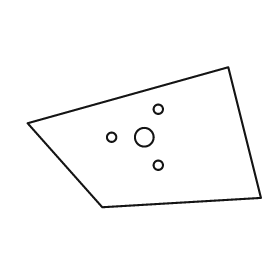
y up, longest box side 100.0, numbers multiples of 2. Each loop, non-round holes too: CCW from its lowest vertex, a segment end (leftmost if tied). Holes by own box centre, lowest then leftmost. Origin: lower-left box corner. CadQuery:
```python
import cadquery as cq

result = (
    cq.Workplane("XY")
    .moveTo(32.0, 0.0)
    .lineTo(100.0, 4.0)
    .lineTo(86.0, 60.0)
    .lineTo(0.0, 36.0)
    .close()
    .moveTo(56.0, 18.0)
    .circle(2.0)
    .moveTo(36.0, 30.0)
    .circle(2.0)
    .moveTo(50.0, 30.0)
    .circle(4.0)
    .moveTo(56.0, 42.0)
    .circle(2.0)
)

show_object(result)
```